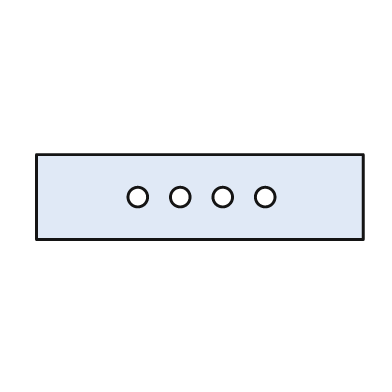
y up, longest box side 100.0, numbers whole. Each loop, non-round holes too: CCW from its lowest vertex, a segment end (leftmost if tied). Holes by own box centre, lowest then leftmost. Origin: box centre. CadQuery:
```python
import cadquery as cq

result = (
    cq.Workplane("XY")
    .moveTo(-50.0, -13.0)
    .lineTo(50.0, -13.0)
    .lineTo(50.0, 13.0)
    .lineTo(-50.0, 13.0)
    .close()
    .moveTo(-19.0, 0.0)
    .circle(3.0)
    .moveTo(-6.0, 0.0)
    .circle(3.0)
    .moveTo(7.0, 0.0)
    .circle(3.0)
    .moveTo(20.0, 0.0)
    .circle(3.0)
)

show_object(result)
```